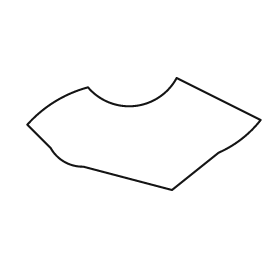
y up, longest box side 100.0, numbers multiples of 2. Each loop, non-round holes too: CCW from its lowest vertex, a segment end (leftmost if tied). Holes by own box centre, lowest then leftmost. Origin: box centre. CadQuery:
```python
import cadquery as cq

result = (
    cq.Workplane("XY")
    .moveTo(12.0, -24.0)
    .lineTo(32.0, -8.0)
    .threePointArc((42.0, -2.0), (50.0, 6.0))
    .lineTo(14.0, 24.0)
    .threePointArc((-4.0, 12.0), (-24.0, 20.0))
    .threePointArc((-38.0, 14.0), (-50.0, 4.0))
    .lineTo(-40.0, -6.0)
    .threePointArc((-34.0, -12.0), (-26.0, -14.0))
    .close()
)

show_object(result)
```